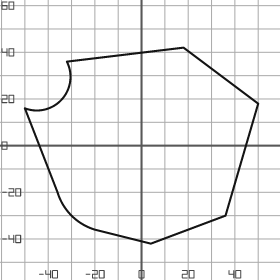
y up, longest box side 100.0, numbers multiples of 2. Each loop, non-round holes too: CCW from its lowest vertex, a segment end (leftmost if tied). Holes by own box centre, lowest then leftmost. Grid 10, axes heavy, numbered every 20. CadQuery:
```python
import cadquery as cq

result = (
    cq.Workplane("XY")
    .moveTo(4.0, -42.0)
    .lineTo(36.0, -30.0)
    .lineTo(50.0, 18.0)
    .lineTo(18.0, 42.0)
    .lineTo(-32.0, 36.0)
    .threePointArc((-34.0, 20.0), (-50.0, 16.0))
    .lineTo(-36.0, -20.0)
    .threePointArc((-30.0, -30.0), (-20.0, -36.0))
    .close()
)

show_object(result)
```